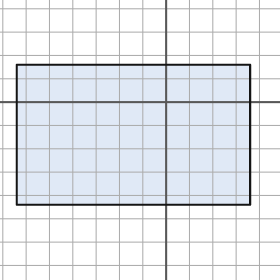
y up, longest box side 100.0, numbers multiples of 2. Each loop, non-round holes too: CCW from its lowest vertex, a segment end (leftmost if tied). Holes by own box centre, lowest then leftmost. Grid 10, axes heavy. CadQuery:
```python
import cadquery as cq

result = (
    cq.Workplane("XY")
    .moveTo(-64.0, -44.0)
    .lineTo(36.0, -44.0)
    .lineTo(36.0, 16.0)
    .lineTo(-64.0, 16.0)
    .close()
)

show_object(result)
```